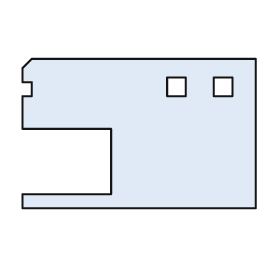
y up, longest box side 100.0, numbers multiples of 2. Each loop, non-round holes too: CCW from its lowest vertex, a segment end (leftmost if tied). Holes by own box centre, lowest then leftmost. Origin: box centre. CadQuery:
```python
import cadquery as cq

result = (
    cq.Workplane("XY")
    .moveTo(-50.0, -32.0)
    .lineTo(50.0, -32.0)
    .lineTo(50.0, 32.0)
    .lineTo(-46.0, 32.0)
    .lineTo(-50.0, 28.0)
    .lineTo(-50.0, 22.0)
    .lineTo(-46.0, 22.0)
    .lineTo(-46.0, 16.0)
    .lineTo(-50.0, 16.0)
    .lineTo(-50.0, 2.0)
    .lineTo(-12.0, 2.0)
    .lineTo(-12.0, -26.0)
    .lineTo(-50.0, -26.0)
    .close()
    .moveTo(12.0, 16.0)
    .lineTo(20.0, 16.0)
    .lineTo(20.0, 24.0)
    .lineTo(12.0, 24.0)
    .close()
    .moveTo(32.0, 16.0)
    .lineTo(40.0, 16.0)
    .lineTo(40.0, 24.0)
    .lineTo(32.0, 24.0)
    .close()
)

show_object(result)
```